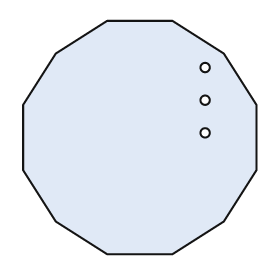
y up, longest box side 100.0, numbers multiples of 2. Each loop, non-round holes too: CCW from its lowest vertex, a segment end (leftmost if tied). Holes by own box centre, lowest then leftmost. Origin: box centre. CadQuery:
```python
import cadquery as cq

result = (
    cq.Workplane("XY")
    .moveTo(-14.0, -50.0)
    .lineTo(14.0, -50.0)
    .lineTo(36.0, -36.0)
    .lineTo(50.0, -14.0)
    .lineTo(50.0, 14.0)
    .lineTo(36.0, 36.0)
    .lineTo(14.0, 50.0)
    .lineTo(-14.0, 50.0)
    .lineTo(-36.0, 36.0)
    .lineTo(-50.0, 14.0)
    .lineTo(-50.0, -14.0)
    .lineTo(-36.0, -36.0)
    .close()
    .moveTo(28.0, 2.0)
    .circle(2.0)
    .moveTo(28.0, 16.0)
    .circle(2.0)
    .moveTo(28.0, 30.0)
    .circle(2.0)
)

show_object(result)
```